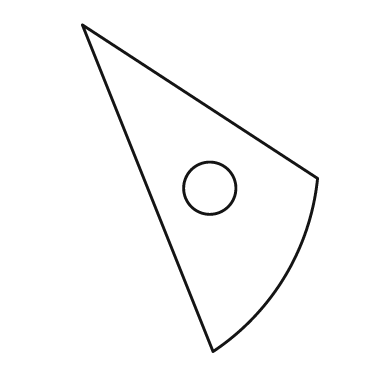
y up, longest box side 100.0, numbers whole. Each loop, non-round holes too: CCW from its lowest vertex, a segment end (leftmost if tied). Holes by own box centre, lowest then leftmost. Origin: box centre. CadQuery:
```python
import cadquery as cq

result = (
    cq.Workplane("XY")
    .moveTo(4.0, -50.0)
    .threePointArc((26.0, -27.0), (36.0, 3.0))
    .lineTo(-36.0, 50.0)
    .close()
    .moveTo(3.0, 0.0)
    .circle(8.0)
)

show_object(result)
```